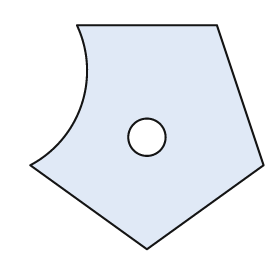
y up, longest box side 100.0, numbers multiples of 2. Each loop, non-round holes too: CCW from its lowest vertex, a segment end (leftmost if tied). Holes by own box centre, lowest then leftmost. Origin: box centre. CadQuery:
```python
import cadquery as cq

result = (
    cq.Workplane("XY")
    .moveTo(0.0, -48.0)
    .lineTo(50.0, -12.0)
    .lineTo(30.0, 48.0)
    .lineTo(-30.0, 48.0)
    .threePointArc((-28.0, 14.0), (-50.0, -12.0))
    .close()
    .moveTo(0.0, 0.0)
    .circle(8.0)
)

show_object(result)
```